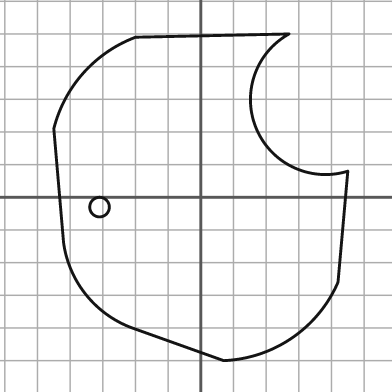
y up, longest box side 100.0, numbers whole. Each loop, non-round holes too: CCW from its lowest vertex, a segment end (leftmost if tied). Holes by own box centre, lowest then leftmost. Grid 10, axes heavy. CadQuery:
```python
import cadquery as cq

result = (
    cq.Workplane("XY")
    .moveTo(7.0, -50.0)
    .threePointArc((28.0, -43.0), (42.0, -26.0))
    .lineTo(45.0, 8.0)
    .threePointArc((17.0, 21.0), (27.0, 50.0))
    .lineTo(-20.0, 49.0)
    .threePointArc((-36.0, 38.0), (-45.0, 21.0))
    .lineTo(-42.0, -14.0)
    .threePointArc((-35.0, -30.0), (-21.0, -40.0))
    .close()
    .moveTo(-31.0, -3.0)
    .circle(3.0)
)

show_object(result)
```